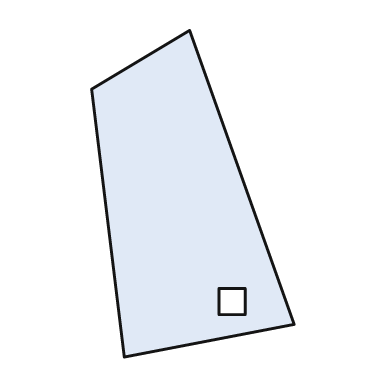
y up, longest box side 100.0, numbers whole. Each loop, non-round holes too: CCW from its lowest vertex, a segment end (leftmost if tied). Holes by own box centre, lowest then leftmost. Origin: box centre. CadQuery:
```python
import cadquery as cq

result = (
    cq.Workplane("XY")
    .moveTo(-21.0, -50.0)
    .lineTo(31.0, -40.0)
    .lineTo(-1.0, 50.0)
    .lineTo(-31.0, 32.0)
    .close()
    .moveTo(8.0, -37.0)
    .lineTo(16.0, -37.0)
    .lineTo(16.0, -29.0)
    .lineTo(8.0, -29.0)
    .close()
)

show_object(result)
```